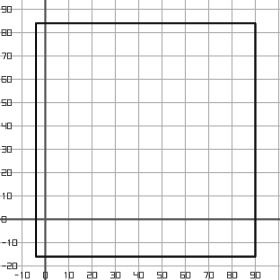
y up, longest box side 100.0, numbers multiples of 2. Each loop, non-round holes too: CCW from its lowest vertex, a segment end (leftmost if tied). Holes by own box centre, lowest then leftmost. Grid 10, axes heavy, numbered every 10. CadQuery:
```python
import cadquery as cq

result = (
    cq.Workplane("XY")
    .moveTo(-4.0, -16.0)
    .lineTo(90.0, -16.0)
    .lineTo(90.0, 84.0)
    .lineTo(-4.0, 84.0)
    .close()
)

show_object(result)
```